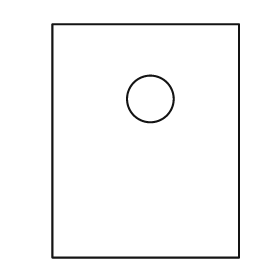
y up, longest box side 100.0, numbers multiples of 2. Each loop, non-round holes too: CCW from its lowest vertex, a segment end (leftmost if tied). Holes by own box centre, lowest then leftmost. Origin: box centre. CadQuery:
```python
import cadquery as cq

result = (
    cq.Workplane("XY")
    .moveTo(-40.0, -50.0)
    .lineTo(40.0, -50.0)
    .lineTo(40.0, 50.0)
    .lineTo(-40.0, 50.0)
    .close()
    .moveTo(2.0, 18.0)
    .circle(10.0)
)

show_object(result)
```